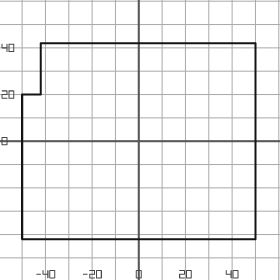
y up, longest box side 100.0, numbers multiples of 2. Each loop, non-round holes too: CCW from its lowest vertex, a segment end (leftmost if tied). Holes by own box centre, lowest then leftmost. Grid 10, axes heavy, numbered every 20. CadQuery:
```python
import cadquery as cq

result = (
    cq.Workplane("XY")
    .moveTo(-50.0, -42.0)
    .lineTo(50.0, -42.0)
    .lineTo(50.0, 42.0)
    .lineTo(-42.0, 42.0)
    .lineTo(-42.0, 20.0)
    .lineTo(-50.0, 20.0)
    .close()
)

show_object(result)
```